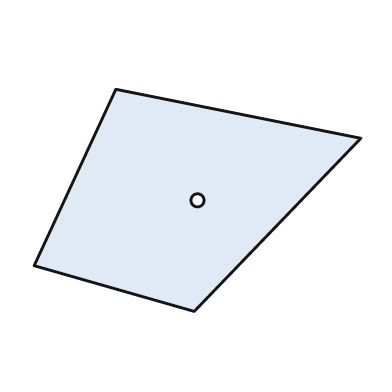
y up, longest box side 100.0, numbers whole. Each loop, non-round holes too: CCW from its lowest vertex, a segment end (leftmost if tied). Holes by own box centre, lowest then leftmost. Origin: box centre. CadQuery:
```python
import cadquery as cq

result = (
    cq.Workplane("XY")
    .moveTo(-1.0, -34.0)
    .lineTo(50.0, 19.0)
    .lineTo(-25.0, 34.0)
    .lineTo(-50.0, -20.0)
    .close()
    .moveTo(0.0, 0.0)
    .circle(2.0)
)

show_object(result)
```